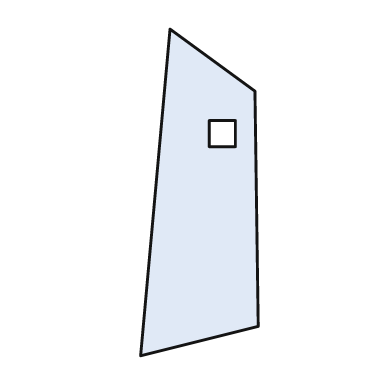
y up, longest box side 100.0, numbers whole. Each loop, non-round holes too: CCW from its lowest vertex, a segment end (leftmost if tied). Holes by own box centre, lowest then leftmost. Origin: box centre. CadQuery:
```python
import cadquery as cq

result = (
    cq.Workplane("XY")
    .moveTo(-18.0, -50.0)
    .lineTo(18.0, -41.0)
    .lineTo(17.0, 31.0)
    .lineTo(-9.0, 50.0)
    .close()
    .moveTo(3.0, 14.0)
    .lineTo(11.0, 14.0)
    .lineTo(11.0, 22.0)
    .lineTo(3.0, 22.0)
    .close()
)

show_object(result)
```